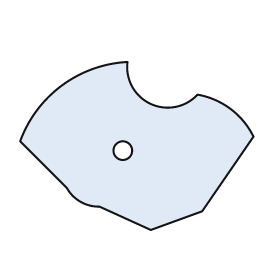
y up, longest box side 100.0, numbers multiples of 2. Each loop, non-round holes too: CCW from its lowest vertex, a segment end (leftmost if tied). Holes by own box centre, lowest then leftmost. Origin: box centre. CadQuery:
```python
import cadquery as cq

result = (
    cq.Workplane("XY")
    .moveTo(6.0, -36.0)
    .lineTo(28.0, -28.0)
    .lineTo(50.0, 4.0)
    .threePointArc((40.0, 16.0), (26.0, 22.0))
    .threePointArc((6.0, 18.0), (-4.0, 36.0))
    .threePointArc((-32.0, 26.0), (-50.0, 2.0))
    .lineTo(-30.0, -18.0)
    .threePointArc((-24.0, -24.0), (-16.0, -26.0))
    .close()
    .moveTo(-6.0, -2.0)
    .circle(4.0)
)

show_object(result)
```